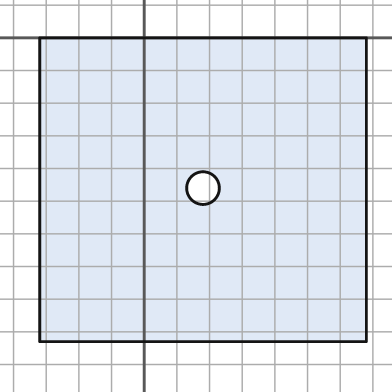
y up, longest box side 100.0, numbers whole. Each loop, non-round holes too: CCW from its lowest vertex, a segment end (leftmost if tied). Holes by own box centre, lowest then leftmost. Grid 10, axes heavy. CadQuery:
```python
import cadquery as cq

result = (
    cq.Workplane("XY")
    .moveTo(-32.0, -93.0)
    .lineTo(68.0, -93.0)
    .lineTo(68.0, 0.0)
    .lineTo(-32.0, 0.0)
    .close()
    .moveTo(18.0, -46.0)
    .circle(5.0)
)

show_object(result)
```